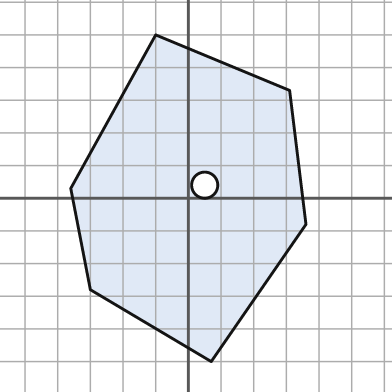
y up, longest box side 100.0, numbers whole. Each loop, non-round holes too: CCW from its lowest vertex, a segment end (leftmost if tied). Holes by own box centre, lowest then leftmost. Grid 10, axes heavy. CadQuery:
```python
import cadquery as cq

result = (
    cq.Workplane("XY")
    .moveTo(7.0, -50.0)
    .lineTo(36.0, -8.0)
    .lineTo(31.0, 33.0)
    .lineTo(-10.0, 50.0)
    .lineTo(-36.0, 3.0)
    .lineTo(-30.0, -28.0)
    .close()
    .moveTo(5.0, 4.0)
    .circle(4.0)
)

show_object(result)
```